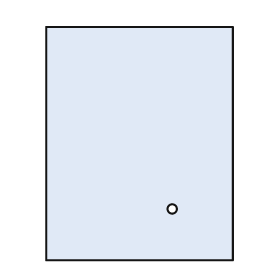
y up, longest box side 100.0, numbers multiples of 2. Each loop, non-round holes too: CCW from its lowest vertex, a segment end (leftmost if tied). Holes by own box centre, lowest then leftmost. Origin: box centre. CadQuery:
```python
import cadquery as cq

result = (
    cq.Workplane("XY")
    .moveTo(-40.0, -50.0)
    .lineTo(40.0, -50.0)
    .lineTo(40.0, 50.0)
    .lineTo(-40.0, 50.0)
    .close()
    .moveTo(14.0, -28.0)
    .circle(2.0)
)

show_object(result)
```